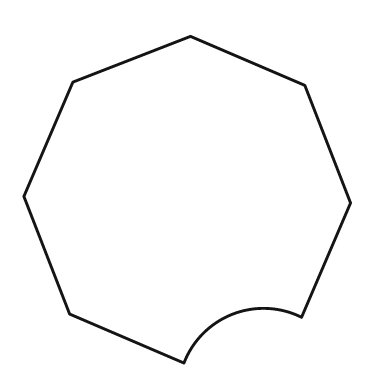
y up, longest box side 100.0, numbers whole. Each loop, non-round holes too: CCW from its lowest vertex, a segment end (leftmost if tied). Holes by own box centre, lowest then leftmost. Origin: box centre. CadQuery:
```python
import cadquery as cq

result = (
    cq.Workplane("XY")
    .moveTo(-1.0, -50.0)
    .threePointArc((14.0, -35.0), (35.0, -36.0))
    .lineTo(50.0, -1.0)
    .lineTo(36.0, 35.0)
    .lineTo(1.0, 50.0)
    .lineTo(-35.0, 36.0)
    .lineTo(-50.0, 1.0)
    .lineTo(-36.0, -35.0)
    .close()
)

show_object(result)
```